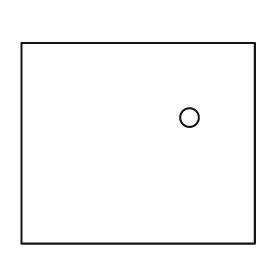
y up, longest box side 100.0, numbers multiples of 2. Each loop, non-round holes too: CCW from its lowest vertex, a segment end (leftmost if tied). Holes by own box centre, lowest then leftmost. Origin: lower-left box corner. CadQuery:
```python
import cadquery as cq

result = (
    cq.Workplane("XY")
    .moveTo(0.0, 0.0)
    .lineTo(100.0, 0.0)
    .lineTo(100.0, 86.0)
    .lineTo(0.0, 86.0)
    .close()
    .moveTo(72.0, 54.0)
    .circle(4.0)
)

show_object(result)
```